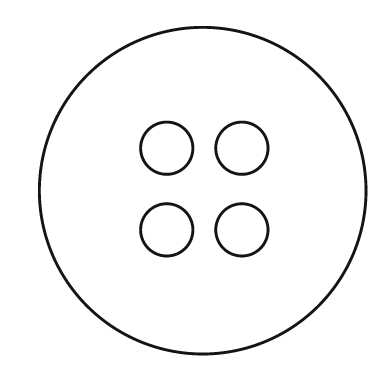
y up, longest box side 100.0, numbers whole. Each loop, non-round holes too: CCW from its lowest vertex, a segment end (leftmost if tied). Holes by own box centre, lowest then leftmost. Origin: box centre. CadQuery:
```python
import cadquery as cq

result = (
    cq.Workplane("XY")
    .moveTo(0.0, 0.0)
    .circle(50.0)
    .moveTo(-11.0, -12.0)
    .circle(8.0)
    .moveTo(12.0, -12.0)
    .circle(8.0)
    .moveTo(-11.0, 13.0)
    .circle(8.0)
    .moveTo(12.0, 13.0)
    .circle(8.0)
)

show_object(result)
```